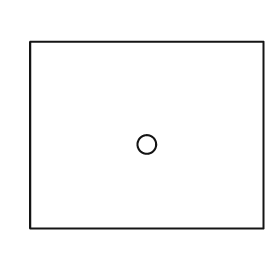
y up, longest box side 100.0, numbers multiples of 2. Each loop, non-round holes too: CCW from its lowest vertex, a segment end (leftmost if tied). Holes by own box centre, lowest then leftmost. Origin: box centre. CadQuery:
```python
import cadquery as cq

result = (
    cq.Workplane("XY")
    .moveTo(-50.0, -40.0)
    .lineTo(50.0, -40.0)
    .lineTo(50.0, 40.0)
    .lineTo(-50.0, 40.0)
    .close()
    .moveTo(0.0, -4.0)
    .circle(4.0)
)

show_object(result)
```